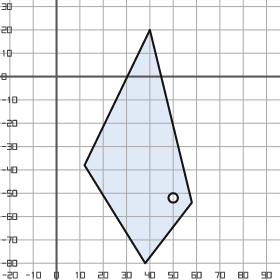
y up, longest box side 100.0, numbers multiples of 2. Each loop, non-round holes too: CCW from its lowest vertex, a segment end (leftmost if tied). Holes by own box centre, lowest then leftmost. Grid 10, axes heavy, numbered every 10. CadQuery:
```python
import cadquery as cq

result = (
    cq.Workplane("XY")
    .moveTo(38.0, -80.0)
    .lineTo(58.0, -54.0)
    .lineTo(40.0, 20.0)
    .lineTo(12.0, -38.0)
    .close()
    .moveTo(50.0, -52.0)
    .circle(2.0)
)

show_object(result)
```